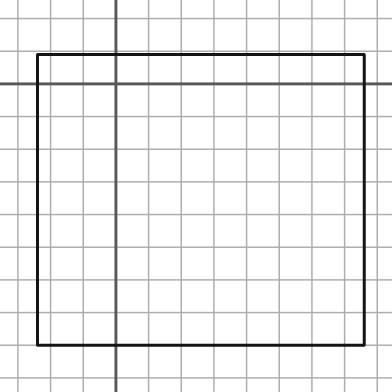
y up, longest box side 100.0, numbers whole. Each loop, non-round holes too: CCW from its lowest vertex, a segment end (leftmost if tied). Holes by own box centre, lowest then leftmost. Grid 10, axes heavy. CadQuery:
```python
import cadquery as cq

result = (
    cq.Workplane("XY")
    .moveTo(-24.0, -80.0)
    .lineTo(76.0, -80.0)
    .lineTo(76.0, 9.0)
    .lineTo(-24.0, 9.0)
    .close()
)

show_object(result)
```